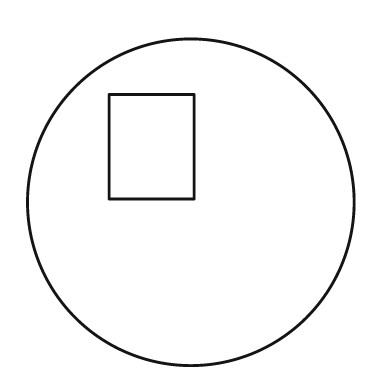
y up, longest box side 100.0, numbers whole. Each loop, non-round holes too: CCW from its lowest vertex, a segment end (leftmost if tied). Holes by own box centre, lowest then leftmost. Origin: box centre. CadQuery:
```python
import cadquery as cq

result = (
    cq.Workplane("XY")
    .moveTo(0.0, 0.0)
    .circle(50.0)
    .moveTo(-25.0, 1.0)
    .lineTo(1.0, 1.0)
    .lineTo(1.0, 33.0)
    .lineTo(-25.0, 33.0)
    .close()
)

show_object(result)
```